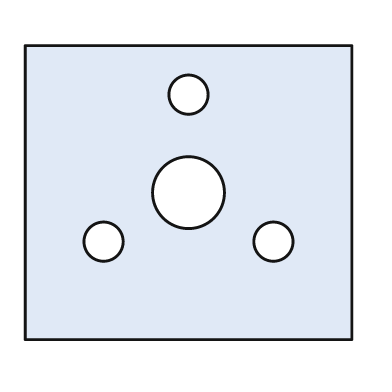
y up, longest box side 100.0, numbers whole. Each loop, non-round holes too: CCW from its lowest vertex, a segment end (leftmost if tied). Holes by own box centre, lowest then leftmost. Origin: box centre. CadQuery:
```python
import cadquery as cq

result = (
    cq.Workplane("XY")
    .moveTo(-50.0, -45.0)
    .lineTo(50.0, -45.0)
    .lineTo(50.0, 45.0)
    .lineTo(-50.0, 45.0)
    .close()
    .moveTo(-26.0, -15.0)
    .circle(6.0)
    .moveTo(26.0, -15.0)
    .circle(6.0)
    .moveTo(0.0, 0.0)
    .circle(11.0)
    .moveTo(0.0, 30.0)
    .circle(6.0)
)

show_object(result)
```